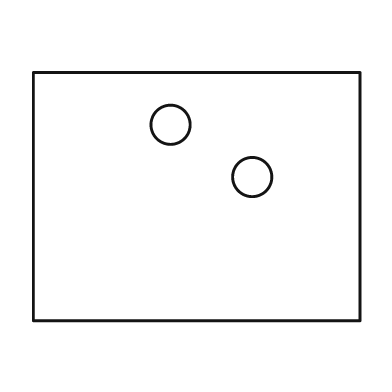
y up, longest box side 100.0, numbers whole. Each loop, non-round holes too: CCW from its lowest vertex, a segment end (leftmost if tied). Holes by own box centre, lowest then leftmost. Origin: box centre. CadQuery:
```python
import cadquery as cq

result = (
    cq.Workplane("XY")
    .moveTo(-50.0, -38.0)
    .lineTo(50.0, -38.0)
    .lineTo(50.0, 38.0)
    .lineTo(-50.0, 38.0)
    .close()
    .moveTo(17.0, 6.0)
    .circle(6.0)
    .moveTo(-8.0, 22.0)
    .circle(6.0)
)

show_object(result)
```